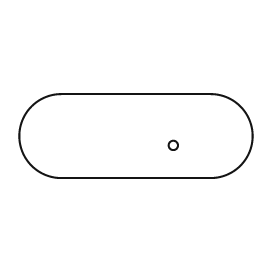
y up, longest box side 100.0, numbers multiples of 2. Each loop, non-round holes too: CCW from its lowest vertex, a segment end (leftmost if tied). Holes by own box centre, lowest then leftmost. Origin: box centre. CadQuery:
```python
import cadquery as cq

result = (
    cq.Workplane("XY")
    .moveTo(-32.0, -18.0)
    .lineTo(32.0, -18.0)
    .threePointArc((50.0, 0.0), (32.0, 18.0))
    .lineTo(-32.0, 18.0)
    .threePointArc((-50.0, 0.0), (-32.0, -18.0))
    .close()
    .moveTo(16.0, -4.0)
    .circle(2.0)
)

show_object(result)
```